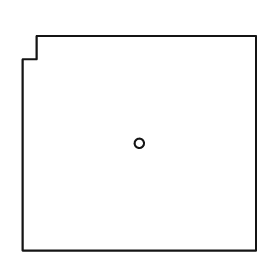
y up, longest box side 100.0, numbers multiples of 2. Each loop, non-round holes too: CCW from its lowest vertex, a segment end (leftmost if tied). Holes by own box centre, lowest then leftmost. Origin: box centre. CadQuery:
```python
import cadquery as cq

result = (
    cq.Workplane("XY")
    .moveTo(-50.0, -46.0)
    .lineTo(50.0, -46.0)
    .lineTo(50.0, 46.0)
    .lineTo(-44.0, 46.0)
    .lineTo(-44.0, 36.0)
    .lineTo(-50.0, 36.0)
    .close()
    .moveTo(0.0, 0.0)
    .circle(2.0)
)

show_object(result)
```